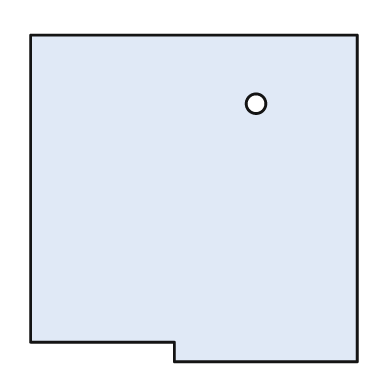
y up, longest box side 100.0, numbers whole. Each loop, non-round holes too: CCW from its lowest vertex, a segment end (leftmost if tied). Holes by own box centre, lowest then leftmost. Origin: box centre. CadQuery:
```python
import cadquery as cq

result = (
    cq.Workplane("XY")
    .moveTo(-6.0, -50.0)
    .lineTo(50.0, -50.0)
    .lineTo(50.0, 50.0)
    .lineTo(-50.0, 50.0)
    .lineTo(-50.0, -44.0)
    .lineTo(-6.0, -44.0)
    .close()
    .moveTo(19.0, 29.0)
    .circle(3.0)
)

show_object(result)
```